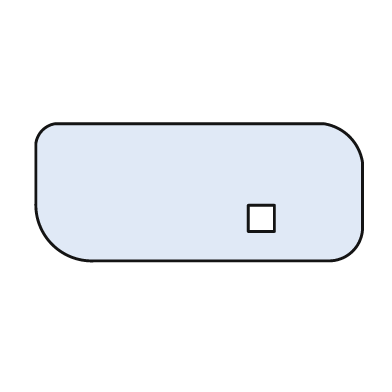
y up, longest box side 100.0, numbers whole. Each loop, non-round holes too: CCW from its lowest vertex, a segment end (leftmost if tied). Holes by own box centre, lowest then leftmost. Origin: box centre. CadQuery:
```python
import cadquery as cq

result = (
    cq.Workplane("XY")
    .moveTo(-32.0, -21.0)
    .lineTo(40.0, -21.0)
    .threePointArc((47.0, -18.0), (50.0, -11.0))
    .lineTo(50.0, 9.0)
    .threePointArc((46.0, 17.0), (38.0, 21.0))
    .lineTo(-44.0, 21.0)
    .threePointArc((-48.0, 19.0), (-50.0, 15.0))
    .lineTo(-50.0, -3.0)
    .threePointArc((-45.0, -16.0), (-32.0, -21.0))
    .close()
    .moveTo(15.0, -12.0)
    .lineTo(23.0, -12.0)
    .lineTo(23.0, -4.0)
    .lineTo(15.0, -4.0)
    .close()
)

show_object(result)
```